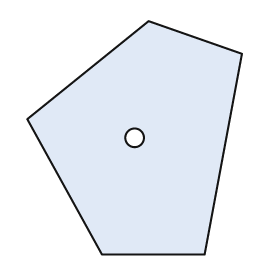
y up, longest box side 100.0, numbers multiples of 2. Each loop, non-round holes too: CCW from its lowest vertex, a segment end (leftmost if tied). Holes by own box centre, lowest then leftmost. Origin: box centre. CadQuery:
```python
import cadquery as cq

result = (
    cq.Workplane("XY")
    .moveTo(-14.0, -50.0)
    .lineTo(30.0, -50.0)
    .lineTo(46.0, 36.0)
    .lineTo(6.0, 50.0)
    .lineTo(-46.0, 8.0)
    .close()
    .moveTo(0.0, 0.0)
    .circle(4.0)
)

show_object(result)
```